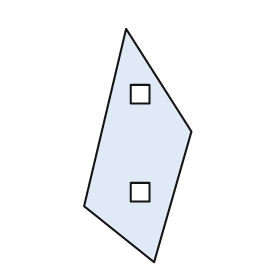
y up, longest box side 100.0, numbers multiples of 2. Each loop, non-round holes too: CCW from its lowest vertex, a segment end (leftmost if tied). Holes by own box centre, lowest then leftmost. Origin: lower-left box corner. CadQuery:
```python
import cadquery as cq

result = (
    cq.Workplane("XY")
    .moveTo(30.0, 0.0)
    .lineTo(46.0, 56.0)
    .lineTo(18.0, 100.0)
    .lineTo(0.0, 24.0)
    .close()
    .moveTo(20.0, 26.0)
    .lineTo(28.0, 26.0)
    .lineTo(28.0, 34.0)
    .lineTo(20.0, 34.0)
    .close()
    .moveTo(20.0, 68.0)
    .lineTo(28.0, 68.0)
    .lineTo(28.0, 76.0)
    .lineTo(20.0, 76.0)
    .close()
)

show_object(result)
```